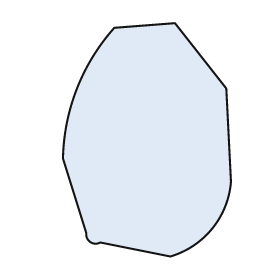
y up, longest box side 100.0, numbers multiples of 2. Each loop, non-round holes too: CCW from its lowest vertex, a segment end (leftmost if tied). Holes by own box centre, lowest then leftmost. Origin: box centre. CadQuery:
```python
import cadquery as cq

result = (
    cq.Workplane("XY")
    .moveTo(10.0, -50.0)
    .threePointArc((28.0, -38.0), (36.0, -18.0))
    .lineTo(34.0, 22.0)
    .lineTo(12.0, 50.0)
    .lineTo(-14.0, 48.0)
    .threePointArc((-30.0, 22.0), (-36.0, -8.0))
    .lineTo(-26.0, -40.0)
    .threePointArc((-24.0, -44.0), (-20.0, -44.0))
    .close()
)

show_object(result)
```